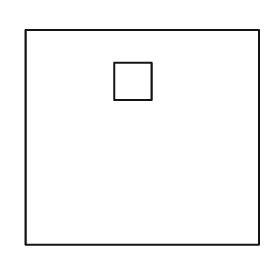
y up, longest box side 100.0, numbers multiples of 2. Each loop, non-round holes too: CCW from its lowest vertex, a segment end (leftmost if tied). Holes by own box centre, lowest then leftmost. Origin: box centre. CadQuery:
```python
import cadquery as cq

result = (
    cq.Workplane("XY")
    .moveTo(-50.0, -46.0)
    .lineTo(50.0, -46.0)
    .lineTo(50.0, 46.0)
    .lineTo(-50.0, 46.0)
    .close()
    .moveTo(-12.0, 16.0)
    .lineTo(4.0, 16.0)
    .lineTo(4.0, 32.0)
    .lineTo(-12.0, 32.0)
    .close()
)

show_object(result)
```